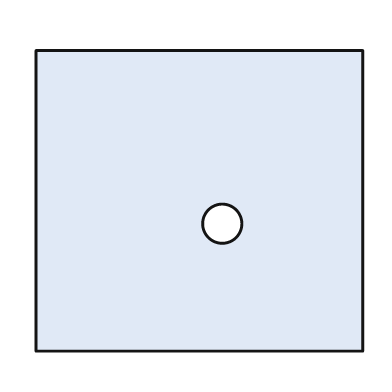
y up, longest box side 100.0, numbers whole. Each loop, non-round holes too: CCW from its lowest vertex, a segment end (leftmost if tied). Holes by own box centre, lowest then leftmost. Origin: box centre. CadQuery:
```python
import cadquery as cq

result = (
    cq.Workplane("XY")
    .moveTo(-50.0, -46.0)
    .lineTo(50.0, -46.0)
    .lineTo(50.0, 46.0)
    .lineTo(-50.0, 46.0)
    .close()
    .moveTo(7.0, -7.0)
    .circle(6.0)
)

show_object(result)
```